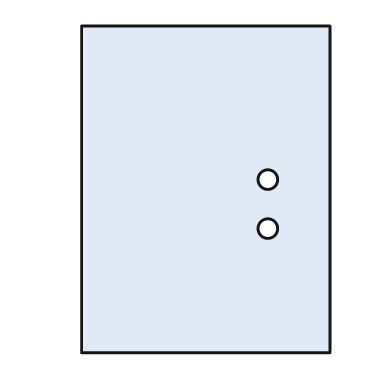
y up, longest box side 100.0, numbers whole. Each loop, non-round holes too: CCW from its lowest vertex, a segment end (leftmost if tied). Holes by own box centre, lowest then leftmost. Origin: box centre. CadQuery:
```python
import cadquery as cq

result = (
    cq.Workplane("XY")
    .moveTo(-38.0, -50.0)
    .lineTo(38.0, -50.0)
    .lineTo(38.0, 50.0)
    .lineTo(-38.0, 50.0)
    .close()
    .moveTo(19.0, -12.0)
    .circle(3.0)
    .moveTo(19.0, 3.0)
    .circle(3.0)
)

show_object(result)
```